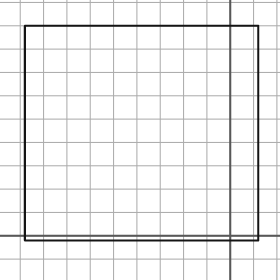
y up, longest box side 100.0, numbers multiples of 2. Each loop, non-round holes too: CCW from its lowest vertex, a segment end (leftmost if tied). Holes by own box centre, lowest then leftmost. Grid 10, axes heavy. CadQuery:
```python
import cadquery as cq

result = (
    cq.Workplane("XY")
    .moveTo(-88.0, -2.0)
    .lineTo(12.0, -2.0)
    .lineTo(12.0, 90.0)
    .lineTo(-88.0, 90.0)
    .close()
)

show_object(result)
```